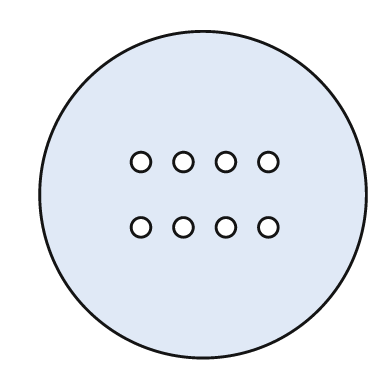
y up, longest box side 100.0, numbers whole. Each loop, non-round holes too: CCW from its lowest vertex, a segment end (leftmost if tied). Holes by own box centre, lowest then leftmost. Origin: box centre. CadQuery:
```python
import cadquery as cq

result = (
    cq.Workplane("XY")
    .moveTo(0.0, 0.0)
    .circle(50.0)
    .moveTo(-19.0, -10.0)
    .circle(3.0)
    .moveTo(-6.0, -10.0)
    .circle(3.0)
    .moveTo(7.0, -10.0)
    .circle(3.0)
    .moveTo(20.0, -10.0)
    .circle(3.0)
    .moveTo(-19.0, 10.0)
    .circle(3.0)
    .moveTo(-6.0, 10.0)
    .circle(3.0)
    .moveTo(7.0, 10.0)
    .circle(3.0)
    .moveTo(20.0, 10.0)
    .circle(3.0)
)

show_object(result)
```